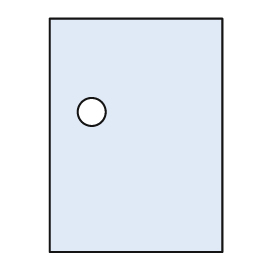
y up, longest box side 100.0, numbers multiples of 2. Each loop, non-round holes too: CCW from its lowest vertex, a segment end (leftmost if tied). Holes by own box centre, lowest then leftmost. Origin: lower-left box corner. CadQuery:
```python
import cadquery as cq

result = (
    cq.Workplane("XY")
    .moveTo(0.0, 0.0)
    .lineTo(74.0, 0.0)
    .lineTo(74.0, 100.0)
    .lineTo(0.0, 100.0)
    .close()
    .moveTo(18.0, 60.0)
    .circle(6.0)
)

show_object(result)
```